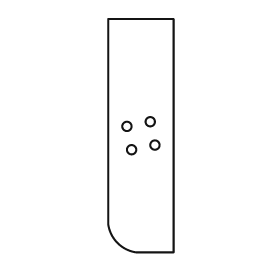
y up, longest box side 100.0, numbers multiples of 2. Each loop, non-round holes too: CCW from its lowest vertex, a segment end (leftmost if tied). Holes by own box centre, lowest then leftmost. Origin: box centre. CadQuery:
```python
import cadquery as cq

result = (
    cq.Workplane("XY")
    .moveTo(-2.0, -50.0)
    .lineTo(14.0, -50.0)
    .lineTo(14.0, 50.0)
    .lineTo(-14.0, 50.0)
    .lineTo(-14.0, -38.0)
    .threePointArc((-10.0, -46.0), (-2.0, -50.0))
    .close()
    .moveTo(-4.0, -6.0)
    .circle(2.0)
    .moveTo(6.0, -4.0)
    .circle(2.0)
    .moveTo(-6.0, 4.0)
    .circle(2.0)
    .moveTo(4.0, 6.0)
    .circle(2.0)
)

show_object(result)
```